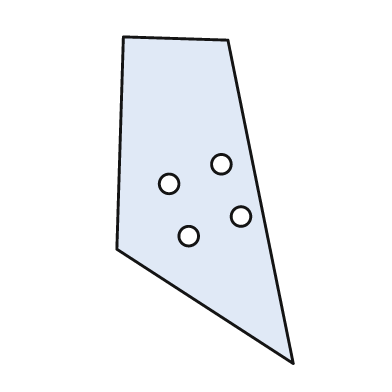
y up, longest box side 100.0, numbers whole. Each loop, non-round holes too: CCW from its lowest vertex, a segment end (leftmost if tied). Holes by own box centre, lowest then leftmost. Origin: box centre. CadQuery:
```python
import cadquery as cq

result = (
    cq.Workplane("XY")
    .moveTo(27.0, -50.0)
    .lineTo(7.0, 49.0)
    .lineTo(-25.0, 50.0)
    .lineTo(-27.0, -15.0)
    .close()
    .moveTo(-5.0, -11.0)
    .circle(3.0)
    .moveTo(11.0, -5.0)
    .circle(3.0)
    .moveTo(-11.0, 5.0)
    .circle(3.0)
    .moveTo(5.0, 11.0)
    .circle(3.0)
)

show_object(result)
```